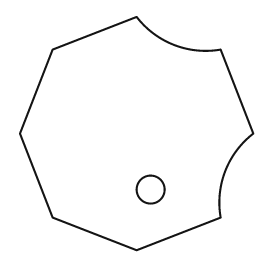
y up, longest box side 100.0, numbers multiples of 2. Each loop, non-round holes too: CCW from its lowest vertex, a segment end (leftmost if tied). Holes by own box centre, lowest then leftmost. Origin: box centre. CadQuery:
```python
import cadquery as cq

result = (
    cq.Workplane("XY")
    .moveTo(0.0, -50.0)
    .lineTo(36.0, -36.0)
    .threePointArc((38.0, -16.0), (50.0, 0.0))
    .lineTo(36.0, 36.0)
    .threePointArc((16.0, 38.0), (0.0, 50.0))
    .lineTo(-36.0, 36.0)
    .lineTo(-50.0, 0.0)
    .lineTo(-36.0, -36.0)
    .close()
    .moveTo(6.0, -24.0)
    .circle(6.0)
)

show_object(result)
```